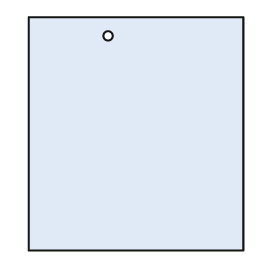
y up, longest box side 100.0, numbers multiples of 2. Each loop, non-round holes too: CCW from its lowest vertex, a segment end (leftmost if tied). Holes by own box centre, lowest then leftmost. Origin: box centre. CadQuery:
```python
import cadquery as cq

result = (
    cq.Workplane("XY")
    .moveTo(-46.0, -50.0)
    .lineTo(46.0, -50.0)
    .lineTo(46.0, 50.0)
    .lineTo(-46.0, 50.0)
    .close()
    .moveTo(-12.0, 42.0)
    .circle(2.0)
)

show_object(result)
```